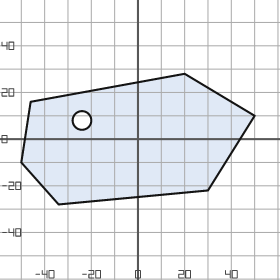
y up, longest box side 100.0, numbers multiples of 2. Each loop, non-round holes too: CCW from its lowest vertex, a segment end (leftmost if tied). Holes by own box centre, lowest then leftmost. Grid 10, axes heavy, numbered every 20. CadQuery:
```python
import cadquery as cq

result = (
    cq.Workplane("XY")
    .moveTo(-34.0, -28.0)
    .lineTo(30.0, -22.0)
    .lineTo(50.0, 10.0)
    .lineTo(20.0, 28.0)
    .lineTo(-46.0, 16.0)
    .lineTo(-50.0, -10.0)
    .close()
    .moveTo(-24.0, 8.0)
    .circle(4.0)
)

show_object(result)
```